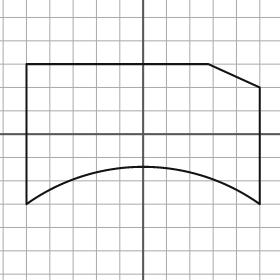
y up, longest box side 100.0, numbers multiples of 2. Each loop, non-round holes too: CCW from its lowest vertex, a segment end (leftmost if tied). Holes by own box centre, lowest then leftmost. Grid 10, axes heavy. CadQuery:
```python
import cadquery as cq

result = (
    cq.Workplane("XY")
    .moveTo(-50.0, -30.0)
    .threePointArc((0.0, -14.0), (50.0, -30.0))
    .lineTo(50.0, 20.0)
    .lineTo(28.0, 30.0)
    .lineTo(-50.0, 30.0)
    .close()
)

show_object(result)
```